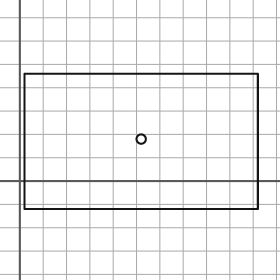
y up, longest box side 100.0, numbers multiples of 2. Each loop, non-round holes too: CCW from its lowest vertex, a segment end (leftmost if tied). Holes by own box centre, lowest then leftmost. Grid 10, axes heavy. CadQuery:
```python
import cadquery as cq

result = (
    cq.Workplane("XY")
    .moveTo(2.0, -12.0)
    .lineTo(102.0, -12.0)
    .lineTo(102.0, 46.0)
    .lineTo(2.0, 46.0)
    .close()
    .moveTo(52.0, 18.0)
    .circle(2.0)
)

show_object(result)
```